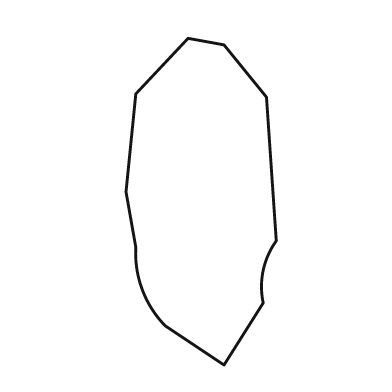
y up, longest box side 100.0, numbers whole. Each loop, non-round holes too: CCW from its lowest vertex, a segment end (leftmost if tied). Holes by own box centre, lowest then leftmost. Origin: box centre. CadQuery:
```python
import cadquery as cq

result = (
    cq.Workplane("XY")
    .moveTo(7.0, -50.0)
    .lineTo(19.0, -31.0)
    .threePointArc((19.0, -21.0), (23.0, -12.0))
    .lineTo(20.0, 32.0)
    .lineTo(7.0, 48.0)
    .lineTo(-4.0, 50.0)
    .lineTo(-20.0, 33.0)
    .lineTo(-23.0, 3.0)
    .lineTo(-20.0, -14.0)
    .threePointArc((-18.0, -27.0), (-11.0, -38.0))
    .close()
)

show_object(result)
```